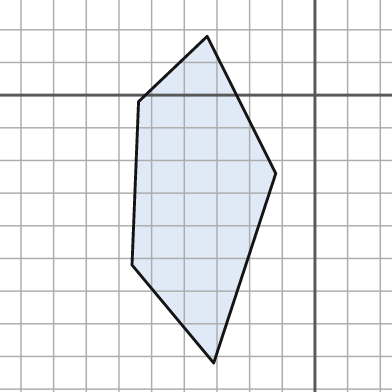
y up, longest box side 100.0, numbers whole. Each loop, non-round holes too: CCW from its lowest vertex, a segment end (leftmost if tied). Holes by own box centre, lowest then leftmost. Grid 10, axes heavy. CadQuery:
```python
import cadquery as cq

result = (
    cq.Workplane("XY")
    .moveTo(-31.0, -82.0)
    .lineTo(-12.0, -24.0)
    .lineTo(-33.0, 18.0)
    .lineTo(-54.0, -2.0)
    .lineTo(-56.0, -52.0)
    .close()
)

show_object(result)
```